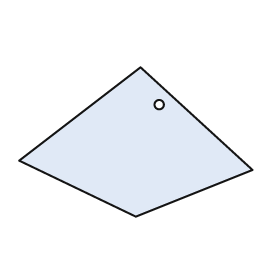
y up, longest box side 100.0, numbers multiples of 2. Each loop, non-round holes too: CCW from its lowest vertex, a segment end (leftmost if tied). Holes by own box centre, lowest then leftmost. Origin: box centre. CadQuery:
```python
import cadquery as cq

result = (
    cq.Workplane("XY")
    .moveTo(0.0, -32.0)
    .lineTo(50.0, -12.0)
    .lineTo(2.0, 32.0)
    .lineTo(-50.0, -8.0)
    .close()
    .moveTo(10.0, 16.0)
    .circle(2.0)
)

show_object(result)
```